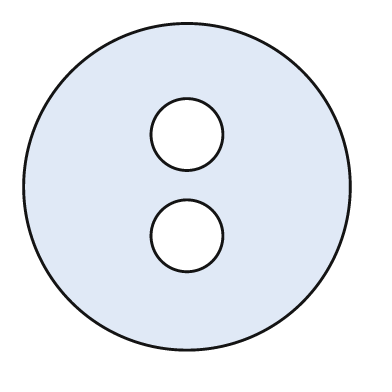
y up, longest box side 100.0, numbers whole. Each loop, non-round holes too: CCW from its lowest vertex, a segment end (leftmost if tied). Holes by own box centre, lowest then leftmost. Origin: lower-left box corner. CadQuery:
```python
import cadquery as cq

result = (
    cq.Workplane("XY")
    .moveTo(50.0, 50.0)
    .circle(50.0)
    .moveTo(50.0, 35.0)
    .circle(11.0)
    .moveTo(50.0, 66.0)
    .circle(11.0)
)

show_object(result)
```